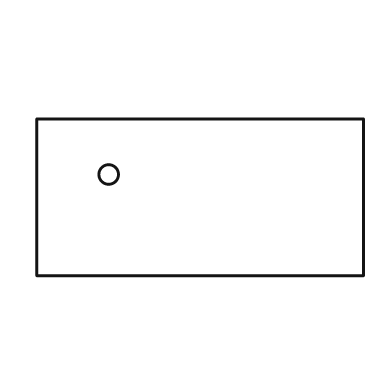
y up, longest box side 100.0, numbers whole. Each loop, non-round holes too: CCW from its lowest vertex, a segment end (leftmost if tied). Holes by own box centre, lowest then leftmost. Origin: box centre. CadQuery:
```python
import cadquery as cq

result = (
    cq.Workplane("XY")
    .moveTo(-50.0, -24.0)
    .lineTo(50.0, -24.0)
    .lineTo(50.0, 24.0)
    .lineTo(-50.0, 24.0)
    .close()
    .moveTo(-28.0, 7.0)
    .circle(3.0)
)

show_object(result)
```